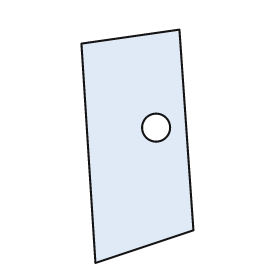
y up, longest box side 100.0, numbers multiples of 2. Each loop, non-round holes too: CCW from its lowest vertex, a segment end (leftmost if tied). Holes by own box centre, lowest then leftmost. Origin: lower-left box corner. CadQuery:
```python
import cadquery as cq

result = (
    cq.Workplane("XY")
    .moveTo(6.0, 0.0)
    .lineTo(48.0, 14.0)
    .lineTo(42.0, 100.0)
    .lineTo(0.0, 94.0)
    .close()
    .moveTo(32.0, 58.0)
    .circle(6.0)
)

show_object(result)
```